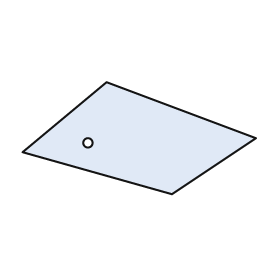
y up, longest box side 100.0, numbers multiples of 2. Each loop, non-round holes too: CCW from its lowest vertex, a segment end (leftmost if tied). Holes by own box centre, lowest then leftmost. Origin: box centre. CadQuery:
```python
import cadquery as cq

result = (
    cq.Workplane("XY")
    .moveTo(14.0, -24.0)
    .lineTo(50.0, 0.0)
    .lineTo(-14.0, 24.0)
    .lineTo(-50.0, -6.0)
    .close()
    .moveTo(-22.0, -2.0)
    .circle(2.0)
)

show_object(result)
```